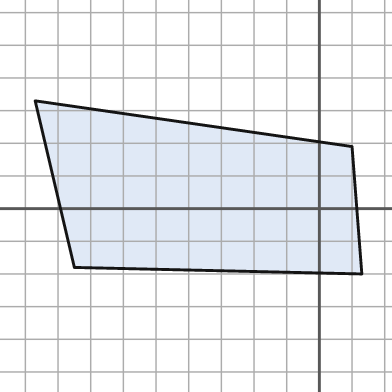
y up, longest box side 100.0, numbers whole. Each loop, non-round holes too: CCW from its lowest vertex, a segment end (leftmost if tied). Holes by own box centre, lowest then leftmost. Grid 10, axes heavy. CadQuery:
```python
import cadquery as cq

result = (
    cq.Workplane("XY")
    .moveTo(13.0, -20.0)
    .lineTo(10.0, 19.0)
    .lineTo(-87.0, 33.0)
    .lineTo(-75.0, -18.0)
    .close()
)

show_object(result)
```